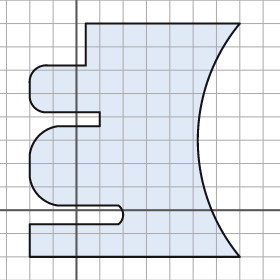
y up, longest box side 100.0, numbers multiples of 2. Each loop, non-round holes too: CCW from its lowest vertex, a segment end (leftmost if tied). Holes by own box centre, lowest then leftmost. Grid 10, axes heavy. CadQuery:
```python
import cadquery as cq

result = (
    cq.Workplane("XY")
    .moveTo(-20.0, -20.0)
    .lineTo(70.0, -20.0)
    .threePointArc((52.0, 30.0), (70.0, 80.0))
    .lineTo(4.0, 80.0)
    .lineTo(4.0, 62.0)
    .lineTo(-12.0, 62.0)
    .threePointArc((-18.0, 60.0), (-20.0, 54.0))
    .lineTo(-20.0, 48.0)
    .threePointArc((-18.0, 44.0), (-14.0, 42.0))
    .lineTo(10.0, 42.0)
    .lineTo(10.0, 36.0)
    .lineTo(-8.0, 36.0)
    .threePointArc((-16.0, 32.0), (-20.0, 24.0))
    .lineTo(-20.0, 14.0)
    .threePointArc((-16.0, 6.0), (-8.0, 2.0))
    .lineTo(18.0, 2.0)
    .threePointArc((20.0, -2.0), (18.0, -6.0))
    .lineTo(-20.0, -6.0)
    .close()
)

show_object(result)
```